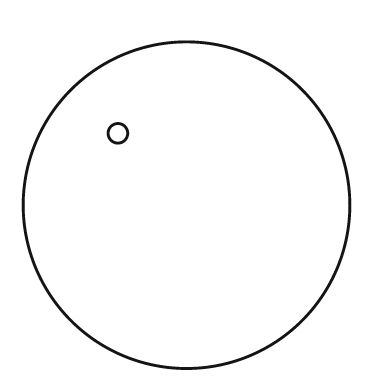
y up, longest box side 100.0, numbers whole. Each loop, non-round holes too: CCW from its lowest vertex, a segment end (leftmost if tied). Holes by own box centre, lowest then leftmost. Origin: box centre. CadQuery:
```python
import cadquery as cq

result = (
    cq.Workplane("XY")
    .moveTo(0.0, 0.0)
    .circle(50.0)
    .moveTo(-21.0, 22.0)
    .circle(3.0)
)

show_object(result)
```